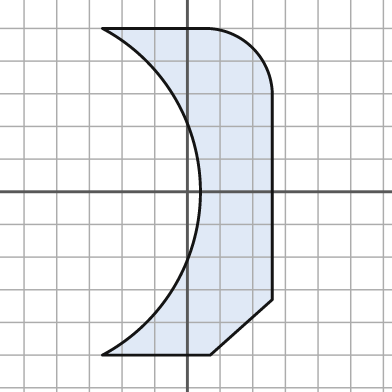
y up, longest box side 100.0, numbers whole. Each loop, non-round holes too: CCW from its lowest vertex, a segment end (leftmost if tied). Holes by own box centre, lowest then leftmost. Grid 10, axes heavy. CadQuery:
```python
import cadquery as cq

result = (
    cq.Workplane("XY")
    .moveTo(-26.0, -50.0)
    .lineTo(7.0, -50.0)
    .lineTo(26.0, -33.0)
    .lineTo(26.0, 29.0)
    .threePointArc((20.0, 44.0), (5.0, 50.0))
    .lineTo(-26.0, 50.0)
    .threePointArc((4.0, 0.0), (-26.0, -50.0))
    .close()
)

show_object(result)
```